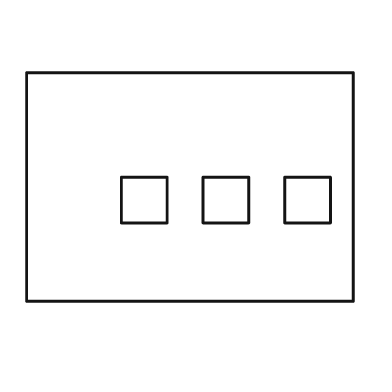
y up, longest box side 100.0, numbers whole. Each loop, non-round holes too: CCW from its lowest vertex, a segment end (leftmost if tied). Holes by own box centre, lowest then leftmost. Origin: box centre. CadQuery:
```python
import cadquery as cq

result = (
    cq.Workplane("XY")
    .moveTo(-50.0, -35.0)
    .lineTo(50.0, -35.0)
    .lineTo(50.0, 35.0)
    .lineTo(-50.0, 35.0)
    .close()
    .moveTo(-21.0, -11.0)
    .lineTo(-7.0, -11.0)
    .lineTo(-7.0, 3.0)
    .lineTo(-21.0, 3.0)
    .close()
    .moveTo(4.0, -11.0)
    .lineTo(18.0, -11.0)
    .lineTo(18.0, 3.0)
    .lineTo(4.0, 3.0)
    .close()
    .moveTo(29.0, -11.0)
    .lineTo(43.0, -11.0)
    .lineTo(43.0, 3.0)
    .lineTo(29.0, 3.0)
    .close()
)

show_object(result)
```